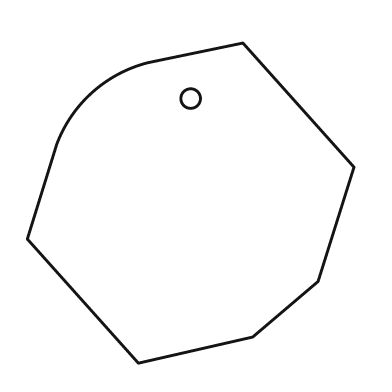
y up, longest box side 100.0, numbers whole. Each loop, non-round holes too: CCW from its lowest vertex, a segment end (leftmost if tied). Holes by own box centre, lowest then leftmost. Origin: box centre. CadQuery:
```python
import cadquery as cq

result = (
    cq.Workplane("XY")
    .moveTo(-16.0, -49.0)
    .lineTo(19.0, -41.0)
    .lineTo(39.0, -24.0)
    .lineTo(50.0, 11.0)
    .lineTo(16.0, 49.0)
    .lineTo(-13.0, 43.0)
    .threePointArc((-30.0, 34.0), (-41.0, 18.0))
    .lineTo(-50.0, -11.0)
    .close()
    .moveTo(0.0, 32.0)
    .circle(3.0)
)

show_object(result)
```